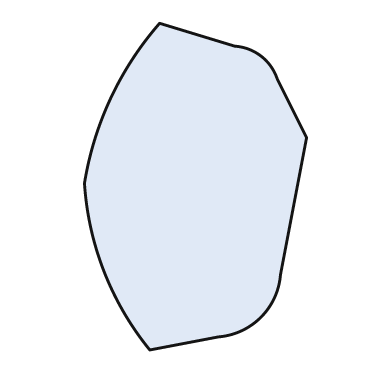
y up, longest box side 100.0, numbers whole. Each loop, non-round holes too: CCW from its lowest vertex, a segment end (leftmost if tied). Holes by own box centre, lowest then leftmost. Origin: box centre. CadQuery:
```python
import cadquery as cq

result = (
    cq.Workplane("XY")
    .moveTo(-14.0, -50.0)
    .lineTo(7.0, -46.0)
    .threePointArc((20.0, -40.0), (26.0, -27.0))
    .lineTo(34.0, 15.0)
    .lineTo(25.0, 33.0)
    .threePointArc((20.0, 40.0), (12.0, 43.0))
    .lineTo(-11.0, 50.0)
    .threePointArc((-26.0, 27.0), (-34.0, 1.0))
    .threePointArc((-28.0, -26.0), (-14.0, -50.0))
    .close()
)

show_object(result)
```